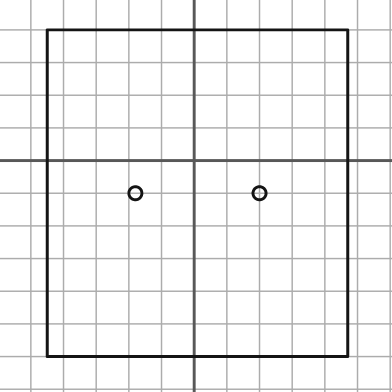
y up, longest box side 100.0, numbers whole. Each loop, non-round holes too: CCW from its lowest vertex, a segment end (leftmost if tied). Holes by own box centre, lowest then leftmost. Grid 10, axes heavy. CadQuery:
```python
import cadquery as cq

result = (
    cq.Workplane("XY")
    .moveTo(-45.0, -60.0)
    .lineTo(47.0, -60.0)
    .lineTo(47.0, 40.0)
    .lineTo(-45.0, 40.0)
    .close()
    .moveTo(-18.0, -10.0)
    .circle(2.0)
    .moveTo(20.0, -10.0)
    .circle(2.0)
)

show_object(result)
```